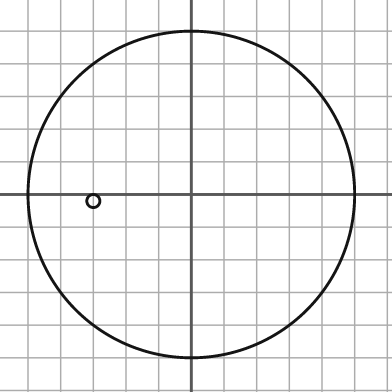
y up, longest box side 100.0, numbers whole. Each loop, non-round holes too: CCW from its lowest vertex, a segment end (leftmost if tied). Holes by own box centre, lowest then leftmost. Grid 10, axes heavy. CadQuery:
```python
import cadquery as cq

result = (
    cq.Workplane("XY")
    .moveTo(0.0, 0.0)
    .circle(50.0)
    .moveTo(-30.0, -2.0)
    .circle(2.0)
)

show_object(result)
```